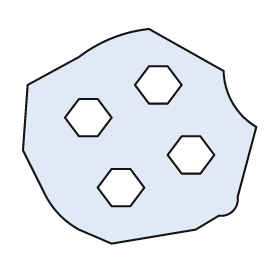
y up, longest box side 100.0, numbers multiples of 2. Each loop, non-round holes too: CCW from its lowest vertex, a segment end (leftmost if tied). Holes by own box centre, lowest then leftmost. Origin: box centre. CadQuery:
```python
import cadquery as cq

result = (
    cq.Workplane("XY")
    .moveTo(-12.0, -46.0)
    .lineTo(24.0, -40.0)
    .lineTo(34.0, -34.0)
    .threePointArc((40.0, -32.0), (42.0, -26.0))
    .lineTo(50.0, 4.0)
    .threePointArc((40.0, 14.0), (36.0, 28.0))
    .lineTo(4.0, 46.0)
    .threePointArc((-12.0, 42.0), (-26.0, 34.0))
    .lineTo(-48.0, 22.0)
    .lineTo(-50.0, -6.0)
    .lineTo(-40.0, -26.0)
    .threePointArc((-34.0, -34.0), (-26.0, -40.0))
    .close()
    .moveTo(-12.0, -30.0)
    .lineTo(-4.0, -30.0)
    .lineTo(2.0, -22.0)
    .lineTo(-4.0, -14.0)
    .lineTo(-12.0, -14.0)
    .lineTo(-18.0, -22.0)
    .close()
    .moveTo(18.0, -16.0)
    .lineTo(26.0, -16.0)
    .lineTo(32.0, -8.0)
    .lineTo(26.0, 0.0)
    .lineTo(18.0, 0.0)
    .lineTo(12.0, -8.0)
    .close()
    .moveTo(-26.0, 0.0)
    .lineTo(-18.0, 0.0)
    .lineTo(-12.0, 8.0)
    .lineTo(-18.0, 16.0)
    .lineTo(-26.0, 16.0)
    .lineTo(-32.0, 8.0)
    .close()
    .moveTo(4.0, 14.0)
    .lineTo(12.0, 14.0)
    .lineTo(18.0, 22.0)
    .lineTo(12.0, 30.0)
    .lineTo(4.0, 30.0)
    .lineTo(-2.0, 22.0)
    .close()
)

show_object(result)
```